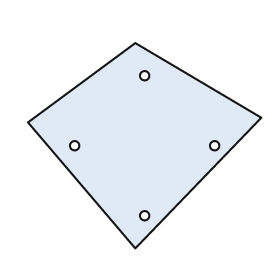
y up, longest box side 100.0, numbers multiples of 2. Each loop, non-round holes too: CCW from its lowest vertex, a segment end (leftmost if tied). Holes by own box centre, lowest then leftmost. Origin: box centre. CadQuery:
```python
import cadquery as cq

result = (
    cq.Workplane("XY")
    .moveTo(-4.0, -44.0)
    .lineTo(50.0, 12.0)
    .lineTo(-4.0, 44.0)
    .lineTo(-50.0, 10.0)
    .close()
    .moveTo(0.0, -30.0)
    .circle(2.0)
    .moveTo(-30.0, 0.0)
    .circle(2.0)
    .moveTo(30.0, 0.0)
    .circle(2.0)
    .moveTo(0.0, 30.0)
    .circle(2.0)
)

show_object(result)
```